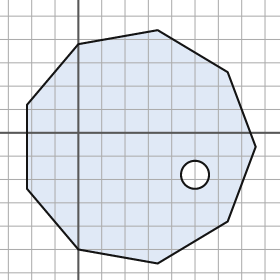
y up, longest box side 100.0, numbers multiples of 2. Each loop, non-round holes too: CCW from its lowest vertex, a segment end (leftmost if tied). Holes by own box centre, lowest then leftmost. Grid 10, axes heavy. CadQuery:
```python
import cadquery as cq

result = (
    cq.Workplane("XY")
    .moveTo(34.0, -56.0)
    .lineTo(64.0, -38.0)
    .lineTo(76.0, -6.0)
    .lineTo(64.0, 26.0)
    .lineTo(34.0, 44.0)
    .lineTo(0.0, 38.0)
    .lineTo(-22.0, 12.0)
    .lineTo(-22.0, -24.0)
    .lineTo(0.0, -50.0)
    .close()
    .moveTo(50.0, -18.0)
    .circle(6.0)
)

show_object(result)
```